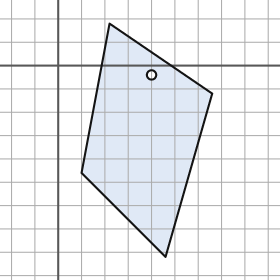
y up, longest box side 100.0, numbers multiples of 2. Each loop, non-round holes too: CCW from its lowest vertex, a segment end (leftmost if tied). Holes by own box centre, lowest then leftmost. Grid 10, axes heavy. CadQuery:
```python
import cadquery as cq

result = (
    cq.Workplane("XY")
    .moveTo(46.0, -82.0)
    .lineTo(66.0, -12.0)
    .lineTo(22.0, 18.0)
    .lineTo(10.0, -46.0)
    .close()
    .moveTo(40.0, -4.0)
    .circle(2.0)
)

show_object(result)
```